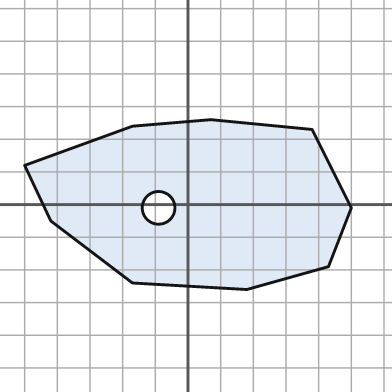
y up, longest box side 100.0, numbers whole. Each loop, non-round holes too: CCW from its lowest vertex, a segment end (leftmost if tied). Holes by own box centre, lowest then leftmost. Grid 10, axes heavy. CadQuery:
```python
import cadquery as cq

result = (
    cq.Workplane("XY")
    .moveTo(18.0, -26.0)
    .lineTo(43.0, -19.0)
    .lineTo(50.0, -1.0)
    .lineTo(38.0, 23.0)
    .lineTo(7.0, 26.0)
    .lineTo(-17.0, 24.0)
    .lineTo(-50.0, 12.0)
    .lineTo(-42.0, -5.0)
    .lineTo(-17.0, -24.0)
    .close()
    .moveTo(-9.0, -1.0)
    .circle(5.0)
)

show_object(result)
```